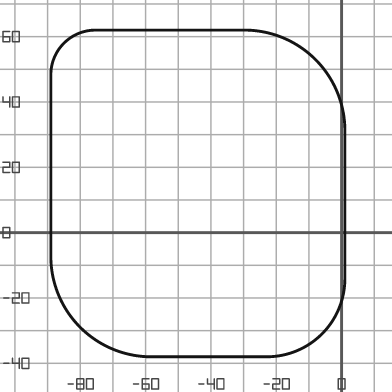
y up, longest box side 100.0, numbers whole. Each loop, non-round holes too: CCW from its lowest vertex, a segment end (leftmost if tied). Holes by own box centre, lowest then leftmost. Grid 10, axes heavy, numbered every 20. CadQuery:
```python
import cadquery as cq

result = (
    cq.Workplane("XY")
    .moveTo(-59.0, -38.0)
    .lineTo(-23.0, -38.0)
    .threePointArc((-6.0, -31.0), (1.0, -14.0))
    .lineTo(1.0, 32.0)
    .threePointArc((-8.0, 53.0), (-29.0, 62.0))
    .lineTo(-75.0, 62.0)
    .threePointArc((-85.0, 58.0), (-89.0, 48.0))
    .lineTo(-89.0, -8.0)
    .threePointArc((-80.0, -29.0), (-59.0, -38.0))
    .close()
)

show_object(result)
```